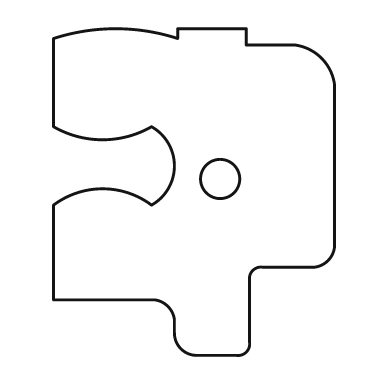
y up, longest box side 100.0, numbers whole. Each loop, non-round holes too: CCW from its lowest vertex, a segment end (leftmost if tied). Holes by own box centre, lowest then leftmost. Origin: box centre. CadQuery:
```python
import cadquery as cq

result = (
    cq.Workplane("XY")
    .moveTo(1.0, -50.0)
    .lineTo(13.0, -50.0)
    .threePointArc((16.0, -49.0), (17.0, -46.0))
    .lineTo(17.0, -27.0)
    .threePointArc((18.0, -24.0), (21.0, -23.0))
    .lineTo(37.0, -23.0)
    .threePointArc((41.0, -21.0), (43.0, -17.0))
    .lineTo(43.0, 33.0)
    .threePointArc((39.0, 41.0), (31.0, 45.0))
    .lineTo(16.0, 45.0)
    .lineTo(16.0, 50.0)
    .lineTo(-5.0, 50.0)
    .lineTo(-5.0, 47.0)
    .threePointArc((-24.0, 50.0), (-43.0, 47.0))
    .lineTo(-43.0, 20.0)
    .threePointArc((-28.0, 16.0), (-13.0, 20.0))
    .threePointArc((-6.0, 8.0), (-13.0, -4.0))
    .threePointArc((-28.0, 1.0), (-43.0, -4.0))
    .lineTo(-43.0, -33.0)
    .lineTo(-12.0, -33.0)
    .threePointArc((-8.0, -35.0), (-6.0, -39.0))
    .lineTo(-6.0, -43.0)
    .threePointArc((-4.0, -48.0), (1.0, -50.0))
    .close()
    .moveTo(8.0, 4.0)
    .circle(6.0)
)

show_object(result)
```